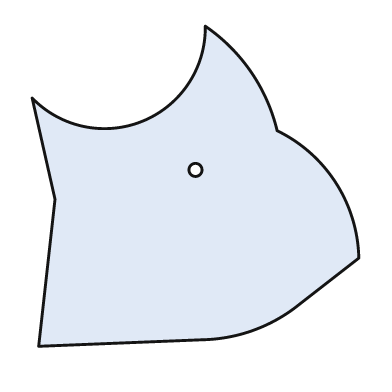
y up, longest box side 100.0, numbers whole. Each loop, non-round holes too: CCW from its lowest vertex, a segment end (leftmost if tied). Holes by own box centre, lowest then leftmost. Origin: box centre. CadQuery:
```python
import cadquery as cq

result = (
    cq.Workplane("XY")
    .moveTo(-48.0, -49.0)
    .lineTo(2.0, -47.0)
    .threePointArc((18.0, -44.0), (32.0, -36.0))
    .lineTo(50.0, -22.0)
    .threePointArc((43.0, 1.0), (25.0, 17.0))
    .threePointArc((17.0, 35.0), (3.0, 49.0))
    .threePointArc((-16.0, 20.0), (-50.0, 27.0))
    .lineTo(-43.0, -4.0)
    .close()
    .moveTo(0.0, 5.0)
    .circle(2.0)
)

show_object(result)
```